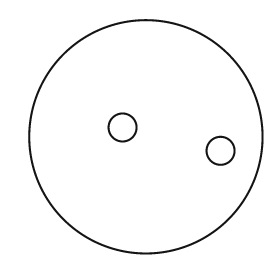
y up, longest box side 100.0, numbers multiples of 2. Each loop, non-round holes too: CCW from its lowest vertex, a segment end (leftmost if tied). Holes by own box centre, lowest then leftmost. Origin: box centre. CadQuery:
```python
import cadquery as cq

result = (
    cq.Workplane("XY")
    .moveTo(0.0, 0.0)
    .circle(50.0)
    .moveTo(32.0, -6.0)
    .circle(6.0)
    .moveTo(-10.0, 4.0)
    .circle(6.0)
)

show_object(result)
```